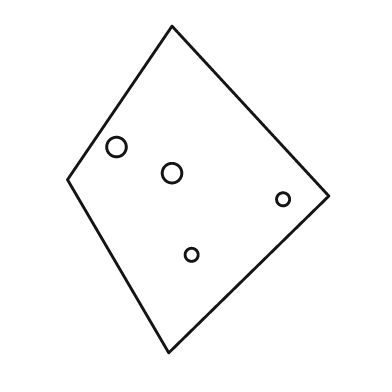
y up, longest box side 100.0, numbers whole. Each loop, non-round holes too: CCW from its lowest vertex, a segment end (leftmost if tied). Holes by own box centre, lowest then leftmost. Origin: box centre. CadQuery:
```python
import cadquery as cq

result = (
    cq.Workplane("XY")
    .moveTo(-9.0, -50.0)
    .lineTo(40.0, -2.0)
    .lineTo(-8.0, 50.0)
    .lineTo(-40.0, 3.0)
    .close()
    .moveTo(-2.0, -20.0)
    .circle(2.0)
    .moveTo(26.0, -3.0)
    .circle(2.0)
    .moveTo(-8.0, 5.0)
    .circle(3.0)
    .moveTo(-25.0, 13.0)
    .circle(3.0)
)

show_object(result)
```